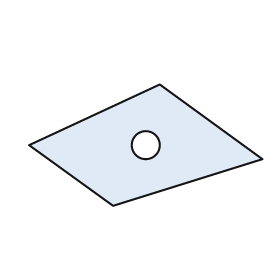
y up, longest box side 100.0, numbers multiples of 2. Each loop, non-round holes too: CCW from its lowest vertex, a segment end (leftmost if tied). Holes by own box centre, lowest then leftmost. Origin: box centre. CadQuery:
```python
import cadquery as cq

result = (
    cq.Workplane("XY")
    .moveTo(-14.0, -26.0)
    .lineTo(50.0, -6.0)
    .lineTo(6.0, 26.0)
    .lineTo(-50.0, 0.0)
    .close()
    .moveTo(0.0, 0.0)
    .circle(6.0)
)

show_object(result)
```